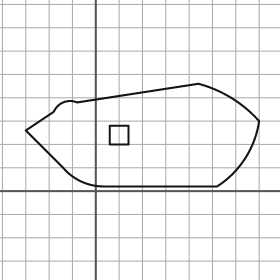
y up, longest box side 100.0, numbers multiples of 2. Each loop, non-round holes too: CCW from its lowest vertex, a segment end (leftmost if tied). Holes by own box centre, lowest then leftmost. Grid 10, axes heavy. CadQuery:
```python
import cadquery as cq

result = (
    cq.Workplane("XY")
    .moveTo(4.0, 2.0)
    .lineTo(52.0, 2.0)
    .threePointArc((64.0, 14.0), (70.0, 30.0))
    .threePointArc((58.0, 40.0), (44.0, 46.0))
    .lineTo(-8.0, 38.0)
    .threePointArc((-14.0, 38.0), (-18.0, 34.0))
    .lineTo(-30.0, 26.0)
    .lineTo(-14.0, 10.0)
    .threePointArc((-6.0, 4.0), (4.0, 2.0))
    .close()
    .moveTo(6.0, 20.0)
    .lineTo(14.0, 20.0)
    .lineTo(14.0, 28.0)
    .lineTo(6.0, 28.0)
    .close()
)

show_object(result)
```